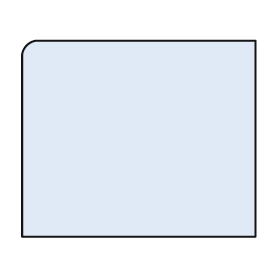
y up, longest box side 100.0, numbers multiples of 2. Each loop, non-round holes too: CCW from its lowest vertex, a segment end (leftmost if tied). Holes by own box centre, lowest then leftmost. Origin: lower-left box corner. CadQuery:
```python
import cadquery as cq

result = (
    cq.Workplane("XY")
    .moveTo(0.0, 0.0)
    .lineTo(100.0, 0.0)
    .lineTo(100.0, 84.0)
    .lineTo(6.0, 84.0)
    .threePointArc((2.0, 82.0), (0.0, 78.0))
    .close()
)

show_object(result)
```